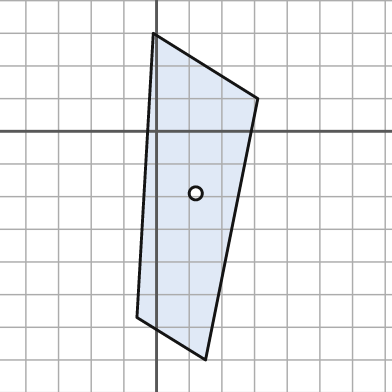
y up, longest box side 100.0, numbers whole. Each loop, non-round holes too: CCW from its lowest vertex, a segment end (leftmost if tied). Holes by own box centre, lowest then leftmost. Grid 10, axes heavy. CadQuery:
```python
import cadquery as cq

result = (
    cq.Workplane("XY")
    .moveTo(15.0, -70.0)
    .lineTo(31.0, 10.0)
    .lineTo(-1.0, 30.0)
    .lineTo(-6.0, -57.0)
    .close()
    .moveTo(12.0, -19.0)
    .circle(2.0)
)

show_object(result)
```